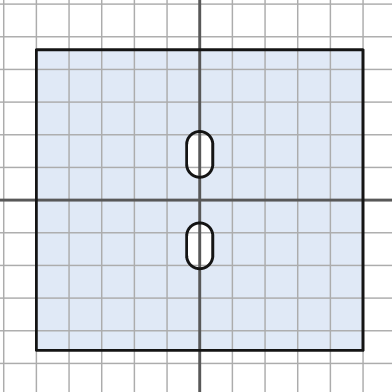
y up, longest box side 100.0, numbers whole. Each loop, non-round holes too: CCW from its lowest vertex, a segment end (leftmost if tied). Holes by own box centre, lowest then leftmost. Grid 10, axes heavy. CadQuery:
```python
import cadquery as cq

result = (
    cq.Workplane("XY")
    .moveTo(-50.0, -46.0)
    .lineTo(50.0, -46.0)
    .lineTo(50.0, 46.0)
    .lineTo(-50.0, 46.0)
    .close()
    .moveTo(-4.0, -17.0)
    .threePointArc((0.0, -21.0), (4.0, -17.0))
    .lineTo(4.0, -11.0)
    .threePointArc((0.0, -7.0), (-4.0, -11.0))
    .close()
    .moveTo(-4.0, 11.0)
    .threePointArc((0.0, 7.0), (4.0, 11.0))
    .lineTo(4.0, 17.0)
    .threePointArc((0.0, 21.0), (-4.0, 17.0))
    .close()
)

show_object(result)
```